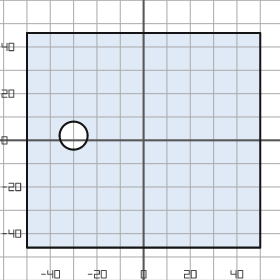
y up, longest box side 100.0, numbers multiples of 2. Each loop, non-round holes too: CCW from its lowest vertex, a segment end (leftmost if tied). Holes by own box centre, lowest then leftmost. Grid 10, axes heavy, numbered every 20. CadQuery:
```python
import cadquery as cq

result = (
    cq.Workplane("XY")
    .moveTo(-50.0, -46.0)
    .lineTo(50.0, -46.0)
    .lineTo(50.0, 46.0)
    .lineTo(-50.0, 46.0)
    .close()
    .moveTo(-30.0, 2.0)
    .circle(6.0)
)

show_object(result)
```